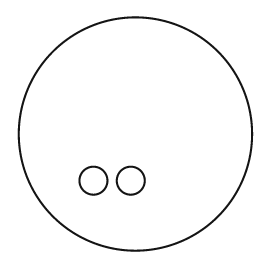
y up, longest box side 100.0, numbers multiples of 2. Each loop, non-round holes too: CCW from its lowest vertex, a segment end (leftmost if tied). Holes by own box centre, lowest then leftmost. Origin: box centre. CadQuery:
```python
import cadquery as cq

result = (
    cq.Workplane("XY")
    .moveTo(0.0, 0.0)
    .circle(50.0)
    .moveTo(-18.0, -20.0)
    .circle(6.0)
    .moveTo(-2.0, -20.0)
    .circle(6.0)
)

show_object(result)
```